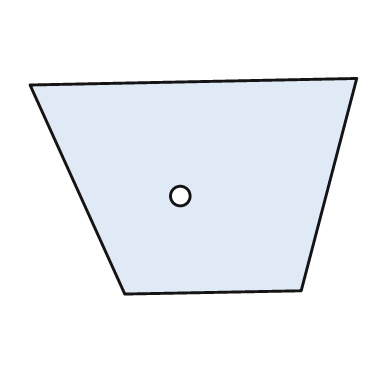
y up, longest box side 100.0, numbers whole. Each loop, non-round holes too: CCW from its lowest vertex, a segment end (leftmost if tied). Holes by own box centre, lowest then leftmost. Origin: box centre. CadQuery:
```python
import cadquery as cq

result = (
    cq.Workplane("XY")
    .moveTo(-21.0, -33.0)
    .lineTo(33.0, -32.0)
    .lineTo(50.0, 33.0)
    .lineTo(-50.0, 31.0)
    .close()
    .moveTo(-4.0, -3.0)
    .circle(3.0)
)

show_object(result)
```